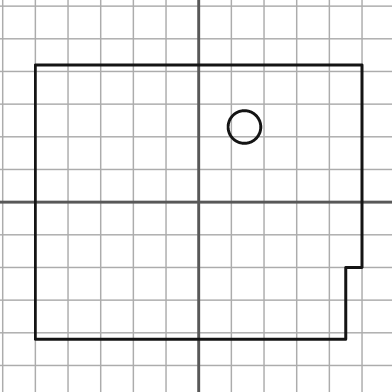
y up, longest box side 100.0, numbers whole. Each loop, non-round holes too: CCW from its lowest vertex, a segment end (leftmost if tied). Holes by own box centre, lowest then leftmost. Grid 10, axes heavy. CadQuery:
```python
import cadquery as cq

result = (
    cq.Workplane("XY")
    .moveTo(-50.0, -42.0)
    .lineTo(45.0, -42.0)
    .lineTo(45.0, -20.0)
    .lineTo(50.0, -20.0)
    .lineTo(50.0, 42.0)
    .lineTo(-50.0, 42.0)
    .close()
    .moveTo(14.0, 23.0)
    .circle(5.0)
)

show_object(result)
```